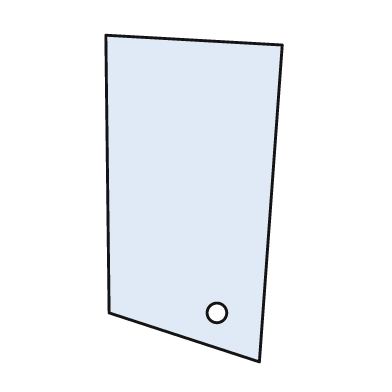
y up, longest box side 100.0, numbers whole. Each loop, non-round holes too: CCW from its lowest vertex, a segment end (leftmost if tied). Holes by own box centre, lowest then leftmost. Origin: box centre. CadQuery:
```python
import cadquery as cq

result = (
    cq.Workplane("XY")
    .moveTo(20.0, -50.0)
    .lineTo(27.0, 47.0)
    .lineTo(-27.0, 50.0)
    .lineTo(-26.0, -35.0)
    .close()
    .moveTo(7.0, -35.0)
    .circle(3.0)
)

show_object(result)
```